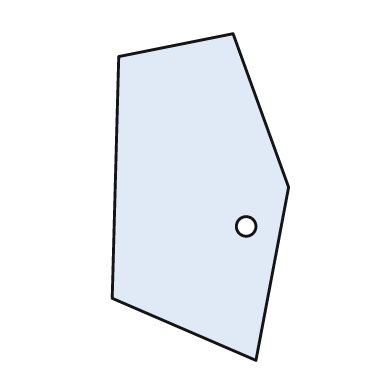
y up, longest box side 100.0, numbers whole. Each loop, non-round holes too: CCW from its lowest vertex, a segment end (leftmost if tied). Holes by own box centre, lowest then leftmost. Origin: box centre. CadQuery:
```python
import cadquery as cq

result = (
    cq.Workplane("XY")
    .moveTo(17.0, -50.0)
    .lineTo(27.0, 3.0)
    .lineTo(10.0, 50.0)
    .lineTo(-25.0, 43.0)
    .lineTo(-27.0, -31.0)
    .close()
    .moveTo(14.0, -9.0)
    .circle(3.0)
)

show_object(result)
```